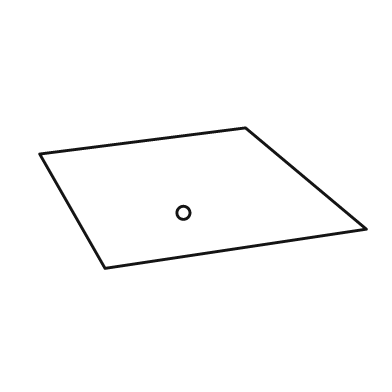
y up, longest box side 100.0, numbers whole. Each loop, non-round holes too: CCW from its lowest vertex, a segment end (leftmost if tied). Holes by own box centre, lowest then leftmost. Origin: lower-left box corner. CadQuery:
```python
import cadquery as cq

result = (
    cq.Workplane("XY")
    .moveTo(20.0, 0.0)
    .lineTo(100.0, 12.0)
    .lineTo(63.0, 43.0)
    .lineTo(0.0, 35.0)
    .close()
    .moveTo(44.0, 17.0)
    .circle(2.0)
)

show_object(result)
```